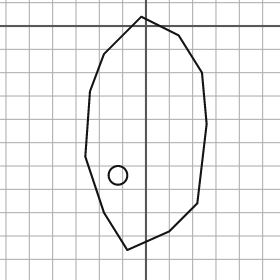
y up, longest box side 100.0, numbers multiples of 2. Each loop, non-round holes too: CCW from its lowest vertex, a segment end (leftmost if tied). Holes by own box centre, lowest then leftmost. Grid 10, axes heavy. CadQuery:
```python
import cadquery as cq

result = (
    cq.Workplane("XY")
    .moveTo(-8.0, -96.0)
    .lineTo(10.0, -88.0)
    .lineTo(22.0, -76.0)
    .lineTo(26.0, -42.0)
    .lineTo(24.0, -20.0)
    .lineTo(14.0, -4.0)
    .lineTo(-2.0, 4.0)
    .lineTo(-18.0, -12.0)
    .lineTo(-24.0, -28.0)
    .lineTo(-26.0, -56.0)
    .lineTo(-18.0, -80.0)
    .close()
    .moveTo(-12.0, -64.0)
    .circle(4.0)
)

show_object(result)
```